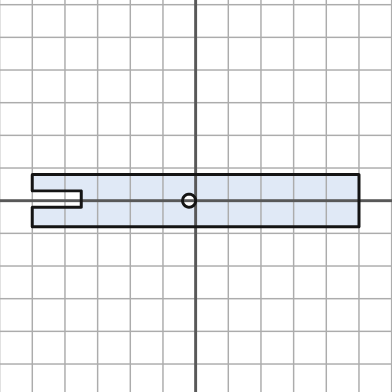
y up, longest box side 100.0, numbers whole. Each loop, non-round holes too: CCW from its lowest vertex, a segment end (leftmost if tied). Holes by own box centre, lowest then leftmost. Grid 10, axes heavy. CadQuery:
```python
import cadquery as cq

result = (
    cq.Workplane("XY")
    .moveTo(-50.0, -8.0)
    .lineTo(50.0, -8.0)
    .lineTo(50.0, 8.0)
    .lineTo(-50.0, 8.0)
    .lineTo(-50.0, 3.0)
    .lineTo(-35.0, 3.0)
    .lineTo(-35.0, -2.0)
    .lineTo(-50.0, -2.0)
    .close()
    .moveTo(-2.0, 0.0)
    .circle(2.0)
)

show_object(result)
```